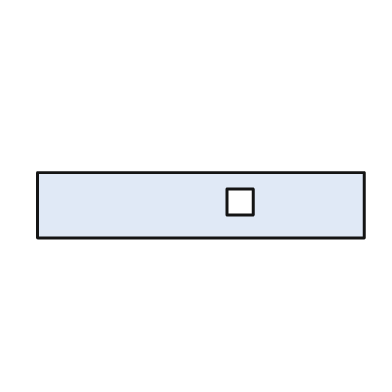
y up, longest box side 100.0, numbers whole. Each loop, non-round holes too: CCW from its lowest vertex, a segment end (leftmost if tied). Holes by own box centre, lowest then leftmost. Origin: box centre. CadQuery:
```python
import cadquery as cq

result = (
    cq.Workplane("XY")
    .moveTo(-50.0, -10.0)
    .lineTo(50.0, -10.0)
    .lineTo(50.0, 10.0)
    .lineTo(-50.0, 10.0)
    .close()
    .moveTo(8.0, -3.0)
    .lineTo(16.0, -3.0)
    .lineTo(16.0, 5.0)
    .lineTo(8.0, 5.0)
    .close()
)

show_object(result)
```